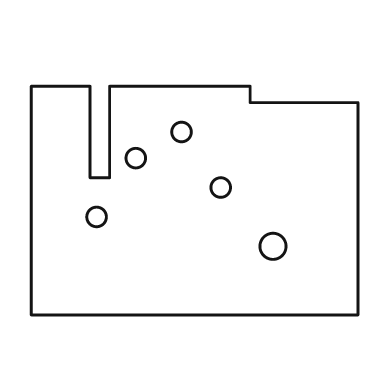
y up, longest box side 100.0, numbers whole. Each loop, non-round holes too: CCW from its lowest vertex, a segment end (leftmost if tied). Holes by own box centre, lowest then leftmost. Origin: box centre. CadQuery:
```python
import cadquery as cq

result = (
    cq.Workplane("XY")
    .moveTo(-50.0, -35.0)
    .lineTo(50.0, -35.0)
    .lineTo(50.0, 30.0)
    .lineTo(17.0, 30.0)
    .lineTo(17.0, 35.0)
    .lineTo(-26.0, 35.0)
    .lineTo(-26.0, 7.0)
    .lineTo(-32.0, 7.0)
    .lineTo(-32.0, 35.0)
    .lineTo(-50.0, 35.0)
    .close()
    .moveTo(24.0, -14.0)
    .circle(4.0)
    .moveTo(-30.0, -5.0)
    .circle(3.0)
    .moveTo(8.0, 4.0)
    .circle(3.0)
    .moveTo(-18.0, 13.0)
    .circle(3.0)
    .moveTo(-4.0, 21.0)
    .circle(3.0)
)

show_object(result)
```